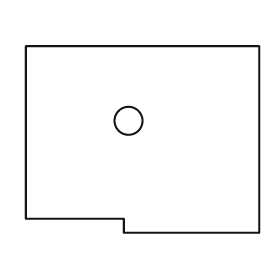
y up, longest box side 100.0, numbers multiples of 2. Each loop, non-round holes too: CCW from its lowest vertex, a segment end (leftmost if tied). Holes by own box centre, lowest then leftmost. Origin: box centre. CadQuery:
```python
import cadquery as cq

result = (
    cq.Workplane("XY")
    .moveTo(-8.0, -40.0)
    .lineTo(50.0, -40.0)
    .lineTo(50.0, 40.0)
    .lineTo(-50.0, 40.0)
    .lineTo(-50.0, -34.0)
    .lineTo(-8.0, -34.0)
    .close()
    .moveTo(-6.0, 8.0)
    .circle(6.0)
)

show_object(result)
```